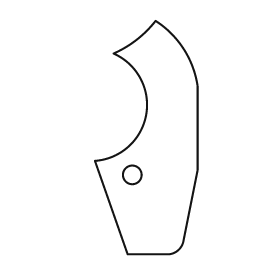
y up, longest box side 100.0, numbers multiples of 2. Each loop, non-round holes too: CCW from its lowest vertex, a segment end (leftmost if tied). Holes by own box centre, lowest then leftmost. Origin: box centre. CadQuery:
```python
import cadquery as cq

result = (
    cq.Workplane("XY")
    .moveTo(-8.0, -50.0)
    .lineTo(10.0, -50.0)
    .threePointArc((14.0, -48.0), (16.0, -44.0))
    .lineTo(22.0, -14.0)
    .lineTo(22.0, 22.0)
    .threePointArc((16.0, 38.0), (4.0, 50.0))
    .threePointArc((-4.0, 42.0), (-14.0, 36.0))
    .threePointArc((0.0, 10.0), (-22.0, -10.0))
    .close()
    .moveTo(-6.0, -16.0)
    .circle(4.0)
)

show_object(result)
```